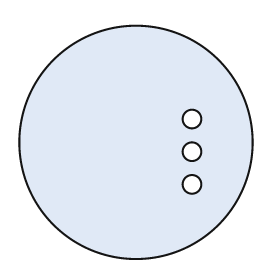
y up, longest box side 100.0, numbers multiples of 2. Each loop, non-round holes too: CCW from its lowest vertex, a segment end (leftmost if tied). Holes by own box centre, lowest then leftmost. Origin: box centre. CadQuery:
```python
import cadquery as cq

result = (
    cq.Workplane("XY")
    .moveTo(0.0, 0.0)
    .circle(50.0)
    .moveTo(24.0, -18.0)
    .circle(4.0)
    .moveTo(24.0, -4.0)
    .circle(4.0)
    .moveTo(24.0, 10.0)
    .circle(4.0)
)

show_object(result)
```